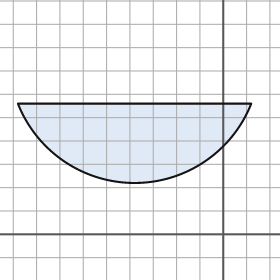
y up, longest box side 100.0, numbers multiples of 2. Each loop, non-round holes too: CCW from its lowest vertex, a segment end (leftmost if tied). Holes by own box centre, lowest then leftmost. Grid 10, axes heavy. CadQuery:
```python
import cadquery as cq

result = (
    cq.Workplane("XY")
    .moveTo(-88.0, 56.0)
    .threePointArc((-38.0, 22.0), (12.0, 56.0))
    .close()
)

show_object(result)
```